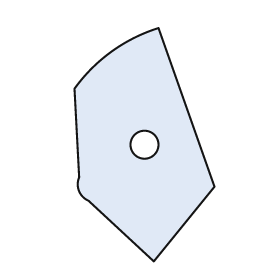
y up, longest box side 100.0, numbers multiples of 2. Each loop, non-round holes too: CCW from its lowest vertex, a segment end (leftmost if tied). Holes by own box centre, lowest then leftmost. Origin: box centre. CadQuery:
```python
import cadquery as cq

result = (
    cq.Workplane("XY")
    .moveTo(4.0, -50.0)
    .lineTo(30.0, -18.0)
    .lineTo(6.0, 50.0)
    .threePointArc((-14.0, 40.0), (-30.0, 24.0))
    .lineTo(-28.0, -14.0)
    .threePointArc((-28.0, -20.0), (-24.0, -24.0))
    .close()
    .moveTo(0.0, 0.0)
    .circle(6.0)
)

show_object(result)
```